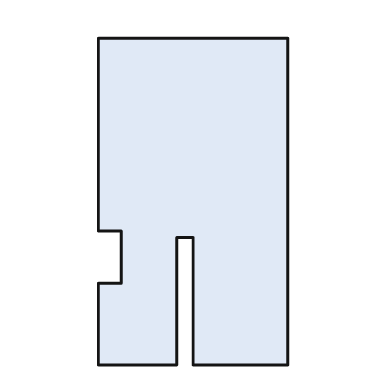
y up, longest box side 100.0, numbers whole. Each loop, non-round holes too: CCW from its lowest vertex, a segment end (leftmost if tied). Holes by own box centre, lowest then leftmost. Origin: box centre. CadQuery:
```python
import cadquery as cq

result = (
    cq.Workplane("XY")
    .moveTo(-29.0, -50.0)
    .lineTo(-5.0, -50.0)
    .lineTo(-5.0, -11.0)
    .lineTo(0.0, -11.0)
    .lineTo(0.0, -50.0)
    .lineTo(29.0, -50.0)
    .lineTo(29.0, 50.0)
    .lineTo(-29.0, 50.0)
    .lineTo(-29.0, -9.0)
    .lineTo(-22.0, -9.0)
    .lineTo(-22.0, -25.0)
    .lineTo(-29.0, -25.0)
    .close()
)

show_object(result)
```